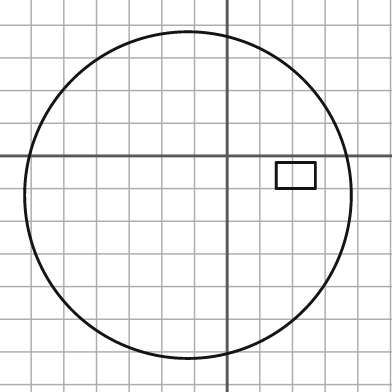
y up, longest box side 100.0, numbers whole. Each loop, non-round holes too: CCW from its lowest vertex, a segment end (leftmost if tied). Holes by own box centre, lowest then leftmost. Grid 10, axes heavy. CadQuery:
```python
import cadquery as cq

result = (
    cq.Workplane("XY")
    .moveTo(-12.0, -12.0)
    .circle(50.0)
    .moveTo(15.0, -10.0)
    .lineTo(27.0, -10.0)
    .lineTo(27.0, -2.0)
    .lineTo(15.0, -2.0)
    .close()
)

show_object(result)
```